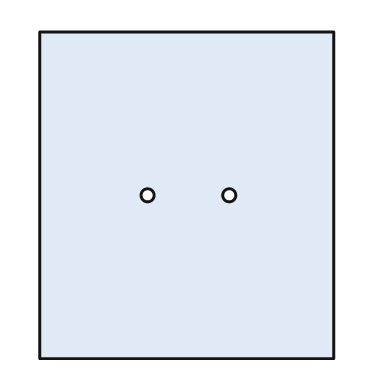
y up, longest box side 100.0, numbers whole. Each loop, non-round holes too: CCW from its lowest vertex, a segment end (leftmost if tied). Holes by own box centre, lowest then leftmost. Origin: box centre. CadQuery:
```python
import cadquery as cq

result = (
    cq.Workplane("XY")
    .moveTo(-45.0, -50.0)
    .lineTo(45.0, -50.0)
    .lineTo(45.0, 50.0)
    .lineTo(-45.0, 50.0)
    .close()
    .moveTo(-12.0, 0.0)
    .circle(2.0)
    .moveTo(13.0, 0.0)
    .circle(2.0)
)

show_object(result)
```